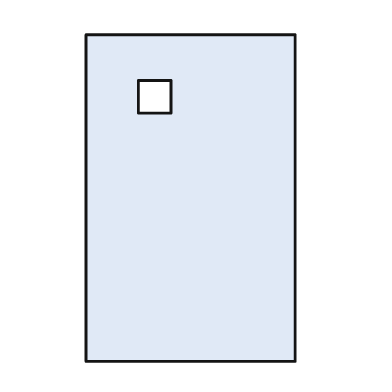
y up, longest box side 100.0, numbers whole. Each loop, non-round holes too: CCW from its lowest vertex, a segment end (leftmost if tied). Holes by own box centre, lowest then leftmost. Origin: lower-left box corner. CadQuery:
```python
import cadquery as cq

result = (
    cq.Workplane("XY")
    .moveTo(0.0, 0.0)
    .lineTo(64.0, 0.0)
    .lineTo(64.0, 100.0)
    .lineTo(0.0, 100.0)
    .close()
    .moveTo(16.0, 76.0)
    .lineTo(26.0, 76.0)
    .lineTo(26.0, 86.0)
    .lineTo(16.0, 86.0)
    .close()
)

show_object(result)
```